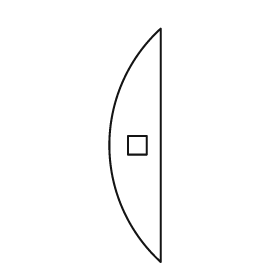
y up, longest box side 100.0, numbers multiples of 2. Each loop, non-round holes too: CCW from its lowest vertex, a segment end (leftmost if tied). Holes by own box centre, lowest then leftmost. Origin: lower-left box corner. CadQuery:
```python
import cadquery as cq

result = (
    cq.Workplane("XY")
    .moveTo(22.0, 0.0)
    .lineTo(22.0, 100.0)
    .threePointArc((0.0, 50.0), (22.0, 0.0))
    .close()
    .moveTo(8.0, 46.0)
    .lineTo(16.0, 46.0)
    .lineTo(16.0, 54.0)
    .lineTo(8.0, 54.0)
    .close()
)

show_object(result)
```